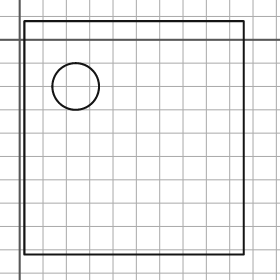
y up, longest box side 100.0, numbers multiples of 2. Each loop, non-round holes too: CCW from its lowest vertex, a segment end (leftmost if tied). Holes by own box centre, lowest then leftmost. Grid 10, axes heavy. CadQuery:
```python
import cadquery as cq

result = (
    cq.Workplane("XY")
    .moveTo(2.0, -92.0)
    .lineTo(96.0, -92.0)
    .lineTo(96.0, 8.0)
    .lineTo(2.0, 8.0)
    .close()
    .moveTo(24.0, -20.0)
    .circle(10.0)
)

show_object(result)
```